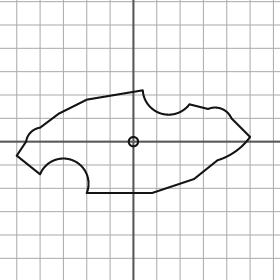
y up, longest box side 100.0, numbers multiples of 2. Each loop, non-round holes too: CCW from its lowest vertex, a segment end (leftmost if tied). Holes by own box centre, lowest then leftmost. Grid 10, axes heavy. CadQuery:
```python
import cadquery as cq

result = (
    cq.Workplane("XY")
    .moveTo(-20.0, -22.0)
    .lineTo(8.0, -22.0)
    .lineTo(26.0, -16.0)
    .lineTo(36.0, -8.0)
    .threePointArc((44.0, -4.0), (50.0, 2.0))
    .lineTo(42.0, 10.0)
    .threePointArc((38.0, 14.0), (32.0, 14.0))
    .lineTo(24.0, 16.0)
    .threePointArc((12.0, 12.0), (4.0, 22.0))
    .lineTo(-20.0, 18.0)
    .lineTo(-32.0, 12.0)
    .lineTo(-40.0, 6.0)
    .threePointArc((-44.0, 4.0), (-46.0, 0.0))
    .lineTo(-50.0, -6.0)
    .lineTo(-40.0, -14.0)
    .threePointArc((-26.0, -8.0), (-20.0, -22.0))
    .close()
    .moveTo(0.0, 0.0)
    .circle(2.0)
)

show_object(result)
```